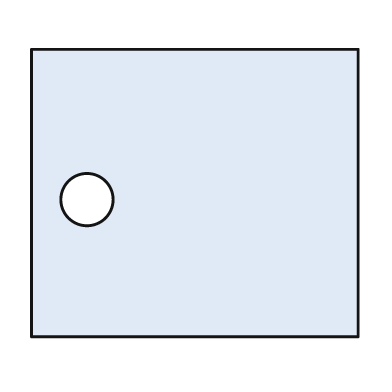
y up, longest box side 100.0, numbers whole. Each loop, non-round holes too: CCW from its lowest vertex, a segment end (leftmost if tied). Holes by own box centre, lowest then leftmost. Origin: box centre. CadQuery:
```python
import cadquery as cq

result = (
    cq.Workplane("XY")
    .moveTo(-50.0, -44.0)
    .lineTo(50.0, -44.0)
    .lineTo(50.0, 44.0)
    .lineTo(-50.0, 44.0)
    .close()
    .moveTo(-33.0, -2.0)
    .circle(8.0)
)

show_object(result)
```